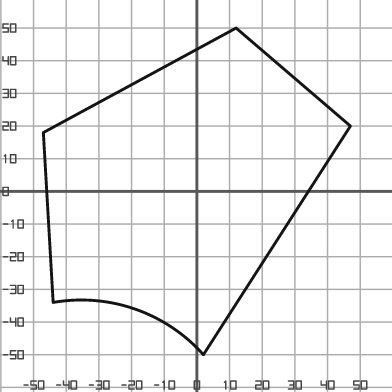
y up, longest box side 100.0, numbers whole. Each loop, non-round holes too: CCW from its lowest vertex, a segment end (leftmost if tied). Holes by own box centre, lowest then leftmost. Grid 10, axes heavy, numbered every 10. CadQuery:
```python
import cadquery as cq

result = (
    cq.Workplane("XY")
    .moveTo(2.0, -50.0)
    .lineTo(47.0, 20.0)
    .lineTo(12.0, 50.0)
    .lineTo(-47.0, 18.0)
    .lineTo(-44.0, -34.0)
    .threePointArc((-19.0, -36.0), (2.0, -50.0))
    .close()
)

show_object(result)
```